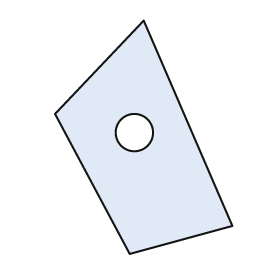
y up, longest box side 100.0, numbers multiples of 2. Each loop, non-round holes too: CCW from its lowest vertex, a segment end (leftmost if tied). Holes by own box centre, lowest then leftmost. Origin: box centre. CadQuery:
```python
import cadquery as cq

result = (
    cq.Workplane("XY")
    .moveTo(-6.0, -50.0)
    .lineTo(38.0, -38.0)
    .lineTo(0.0, 50.0)
    .lineTo(-38.0, 10.0)
    .close()
    .moveTo(-4.0, 2.0)
    .circle(8.0)
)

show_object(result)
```